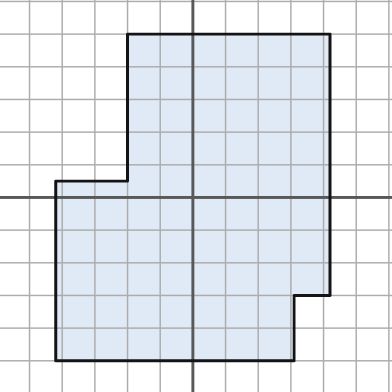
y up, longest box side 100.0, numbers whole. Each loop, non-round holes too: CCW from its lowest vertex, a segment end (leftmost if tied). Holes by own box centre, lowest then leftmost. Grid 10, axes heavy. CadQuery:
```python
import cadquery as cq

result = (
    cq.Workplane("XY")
    .moveTo(-42.0, -50.0)
    .lineTo(31.0, -50.0)
    .lineTo(31.0, -30.0)
    .lineTo(42.0, -30.0)
    .lineTo(42.0, 50.0)
    .lineTo(-20.0, 50.0)
    .lineTo(-20.0, 5.0)
    .lineTo(-42.0, 5.0)
    .close()
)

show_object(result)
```